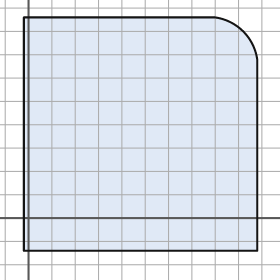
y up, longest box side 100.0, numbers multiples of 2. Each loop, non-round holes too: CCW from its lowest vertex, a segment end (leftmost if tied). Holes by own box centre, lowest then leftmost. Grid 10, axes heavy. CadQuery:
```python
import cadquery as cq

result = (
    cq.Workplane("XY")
    .moveTo(-2.0, -14.0)
    .lineTo(98.0, -14.0)
    .lineTo(98.0, 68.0)
    .threePointArc((92.0, 80.0), (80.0, 86.0))
    .lineTo(-2.0, 86.0)
    .close()
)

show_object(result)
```